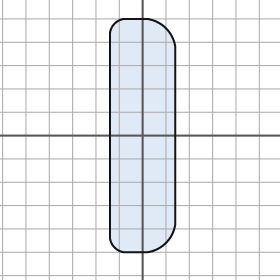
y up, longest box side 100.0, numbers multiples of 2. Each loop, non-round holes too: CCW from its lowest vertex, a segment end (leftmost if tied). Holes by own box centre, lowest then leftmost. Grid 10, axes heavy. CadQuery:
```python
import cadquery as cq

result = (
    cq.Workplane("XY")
    .moveTo(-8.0, -50.0)
    .lineTo(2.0, -50.0)
    .threePointArc((10.0, -46.0), (14.0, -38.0))
    .lineTo(14.0, 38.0)
    .threePointArc((10.0, 46.0), (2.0, 50.0))
    .lineTo(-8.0, 50.0)
    .threePointArc((-12.0, 48.0), (-14.0, 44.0))
    .lineTo(-14.0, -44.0)
    .threePointArc((-12.0, -48.0), (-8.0, -50.0))
    .close()
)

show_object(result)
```